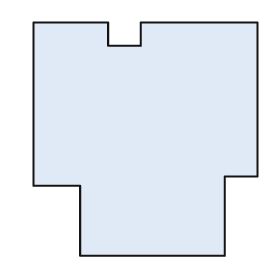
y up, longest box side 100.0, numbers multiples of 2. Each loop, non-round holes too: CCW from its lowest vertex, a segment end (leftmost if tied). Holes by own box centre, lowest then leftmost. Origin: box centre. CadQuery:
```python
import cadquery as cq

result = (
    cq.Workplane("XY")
    .moveTo(-28.0, -50.0)
    .lineTo(34.0, -50.0)
    .lineTo(34.0, -16.0)
    .lineTo(48.0, -16.0)
    .lineTo(48.0, 50.0)
    .lineTo(-2.0, 50.0)
    .lineTo(-2.0, 40.0)
    .lineTo(-16.0, 40.0)
    .lineTo(-16.0, 50.0)
    .lineTo(-48.0, 50.0)
    .lineTo(-48.0, -20.0)
    .lineTo(-28.0, -20.0)
    .close()
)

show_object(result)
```